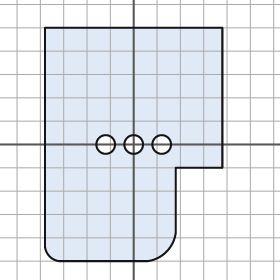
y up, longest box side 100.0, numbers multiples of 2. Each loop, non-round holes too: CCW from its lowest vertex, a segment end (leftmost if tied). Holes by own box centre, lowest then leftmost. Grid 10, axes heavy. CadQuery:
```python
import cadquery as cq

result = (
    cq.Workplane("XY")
    .moveTo(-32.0, -50.0)
    .lineTo(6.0, -50.0)
    .threePointArc((14.0, -46.0), (18.0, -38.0))
    .lineTo(18.0, -10.0)
    .lineTo(38.0, -10.0)
    .lineTo(38.0, 50.0)
    .lineTo(-38.0, 50.0)
    .lineTo(-38.0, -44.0)
    .threePointArc((-36.0, -48.0), (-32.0, -50.0))
    .close()
    .moveTo(-12.0, 0.0)
    .circle(4.0)
    .moveTo(0.0, 0.0)
    .circle(4.0)
    .moveTo(12.0, 0.0)
    .circle(4.0)
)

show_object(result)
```